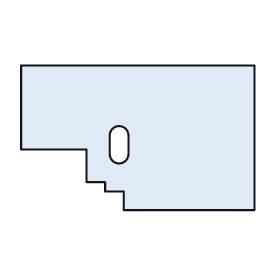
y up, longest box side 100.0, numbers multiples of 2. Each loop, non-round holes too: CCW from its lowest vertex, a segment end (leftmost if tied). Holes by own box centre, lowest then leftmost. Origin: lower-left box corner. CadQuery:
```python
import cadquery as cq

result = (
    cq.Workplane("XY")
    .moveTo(44.0, 0.0)
    .lineTo(100.0, 0.0)
    .lineTo(100.0, 62.0)
    .lineTo(0.0, 62.0)
    .lineTo(0.0, 26.0)
    .lineTo(28.0, 26.0)
    .lineTo(28.0, 12.0)
    .lineTo(36.0, 12.0)
    .lineTo(36.0, 8.0)
    .lineTo(44.0, 8.0)
    .close()
    .moveTo(38.0, 24.0)
    .threePointArc((42.0, 20.0), (46.0, 24.0))
    .lineTo(46.0, 32.0)
    .threePointArc((42.0, 36.0), (38.0, 32.0))
    .close()
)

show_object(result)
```